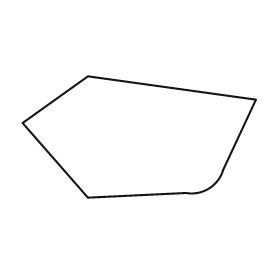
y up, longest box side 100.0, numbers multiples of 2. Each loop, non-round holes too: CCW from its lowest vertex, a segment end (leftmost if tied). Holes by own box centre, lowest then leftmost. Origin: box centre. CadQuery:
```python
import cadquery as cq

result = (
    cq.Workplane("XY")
    .moveTo(-22.0, -26.0)
    .lineTo(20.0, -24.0)
    .threePointArc((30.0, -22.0), (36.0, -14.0))
    .lineTo(50.0, 16.0)
    .lineTo(-22.0, 26.0)
    .lineTo(-50.0, 6.0)
    .close()
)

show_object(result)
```